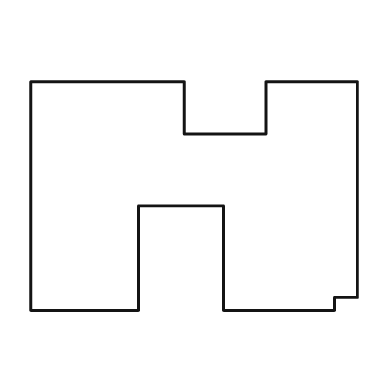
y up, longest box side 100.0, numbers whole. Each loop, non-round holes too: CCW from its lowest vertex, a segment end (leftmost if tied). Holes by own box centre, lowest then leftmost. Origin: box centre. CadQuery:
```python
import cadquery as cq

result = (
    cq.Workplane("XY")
    .moveTo(-50.0, -35.0)
    .lineTo(-17.0, -35.0)
    .lineTo(-17.0, -3.0)
    .lineTo(9.0, -3.0)
    .lineTo(9.0, -35.0)
    .lineTo(43.0, -35.0)
    .lineTo(43.0, -31.0)
    .lineTo(50.0, -31.0)
    .lineTo(50.0, 35.0)
    .lineTo(22.0, 35.0)
    .lineTo(22.0, 19.0)
    .lineTo(-3.0, 19.0)
    .lineTo(-3.0, 35.0)
    .lineTo(-50.0, 35.0)
    .close()
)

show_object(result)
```